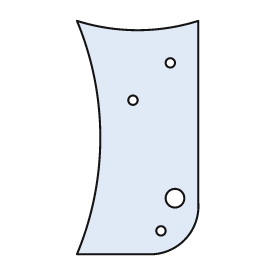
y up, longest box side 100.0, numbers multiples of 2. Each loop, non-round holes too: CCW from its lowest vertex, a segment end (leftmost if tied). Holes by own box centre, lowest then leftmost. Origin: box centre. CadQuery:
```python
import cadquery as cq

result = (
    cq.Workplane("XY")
    .moveTo(-26.0, -50.0)
    .lineTo(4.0, -50.0)
    .threePointArc((20.0, -44.0), (26.0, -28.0))
    .lineTo(26.0, 50.0)
    .threePointArc((0.0, 46.0), (-26.0, 50.0))
    .threePointArc((-16.0, 0.0), (-26.0, -50.0))
    .close()
    .moveTo(10.0, -40.0)
    .circle(2.0)
    .moveTo(16.0, -26.0)
    .circle(4.0)
    .moveTo(-2.0, 16.0)
    .circle(2.0)
    .moveTo(14.0, 32.0)
    .circle(2.0)
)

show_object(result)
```